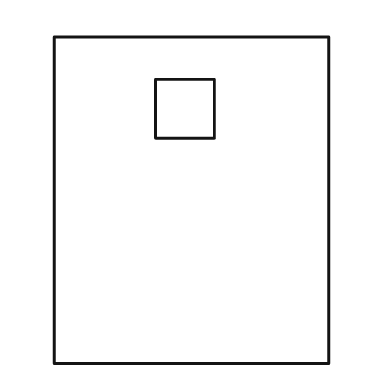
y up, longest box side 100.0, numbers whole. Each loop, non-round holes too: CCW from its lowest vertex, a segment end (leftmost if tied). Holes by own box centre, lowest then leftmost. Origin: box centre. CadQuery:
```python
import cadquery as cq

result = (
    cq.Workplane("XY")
    .moveTo(-42.0, -50.0)
    .lineTo(42.0, -50.0)
    .lineTo(42.0, 50.0)
    .lineTo(-42.0, 50.0)
    .close()
    .moveTo(-11.0, 19.0)
    .lineTo(7.0, 19.0)
    .lineTo(7.0, 37.0)
    .lineTo(-11.0, 37.0)
    .close()
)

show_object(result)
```